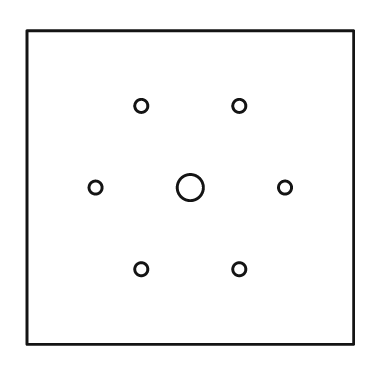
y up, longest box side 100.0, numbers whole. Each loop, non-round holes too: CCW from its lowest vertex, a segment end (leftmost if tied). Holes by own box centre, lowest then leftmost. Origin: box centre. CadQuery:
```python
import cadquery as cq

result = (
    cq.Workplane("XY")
    .moveTo(-50.0, -48.0)
    .lineTo(50.0, -48.0)
    .lineTo(50.0, 48.0)
    .lineTo(-50.0, 48.0)
    .close()
    .moveTo(-15.0, -25.0)
    .circle(2.0)
    .moveTo(15.0, -25.0)
    .circle(2.0)
    .moveTo(-29.0, 0.0)
    .circle(2.0)
    .moveTo(0.0, 0.0)
    .circle(4.0)
    .moveTo(29.0, 0.0)
    .circle(2.0)
    .moveTo(-15.0, 25.0)
    .circle(2.0)
    .moveTo(15.0, 25.0)
    .circle(2.0)
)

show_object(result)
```